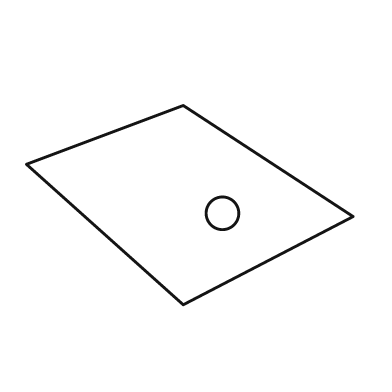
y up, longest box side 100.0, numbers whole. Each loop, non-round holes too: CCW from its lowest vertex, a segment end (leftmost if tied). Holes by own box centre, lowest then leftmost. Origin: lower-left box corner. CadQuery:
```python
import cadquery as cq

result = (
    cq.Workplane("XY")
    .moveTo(48.0, 0.0)
    .lineTo(100.0, 27.0)
    .lineTo(48.0, 61.0)
    .lineTo(0.0, 43.0)
    .close()
    .moveTo(60.0, 28.0)
    .circle(5.0)
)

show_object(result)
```